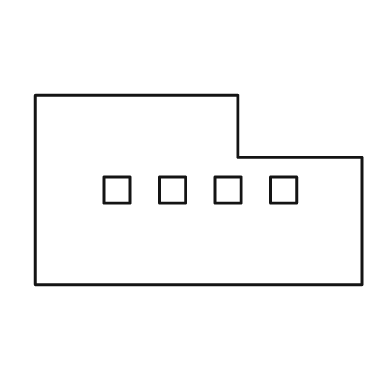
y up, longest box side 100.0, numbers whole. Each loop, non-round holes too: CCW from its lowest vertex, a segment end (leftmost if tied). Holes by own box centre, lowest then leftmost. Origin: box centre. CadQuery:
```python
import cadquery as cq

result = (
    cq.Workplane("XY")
    .moveTo(-50.0, -29.0)
    .lineTo(50.0, -29.0)
    .lineTo(50.0, 10.0)
    .lineTo(12.0, 10.0)
    .lineTo(12.0, 29.0)
    .lineTo(-50.0, 29.0)
    .close()
    .moveTo(-29.0, -4.0)
    .lineTo(-21.0, -4.0)
    .lineTo(-21.0, 4.0)
    .lineTo(-29.0, 4.0)
    .close()
    .moveTo(-12.0, -4.0)
    .lineTo(-4.0, -4.0)
    .lineTo(-4.0, 4.0)
    .lineTo(-12.0, 4.0)
    .close()
    .moveTo(5.0, -4.0)
    .lineTo(13.0, -4.0)
    .lineTo(13.0, 4.0)
    .lineTo(5.0, 4.0)
    .close()
    .moveTo(22.0, -4.0)
    .lineTo(30.0, -4.0)
    .lineTo(30.0, 4.0)
    .lineTo(22.0, 4.0)
    .close()
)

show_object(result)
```